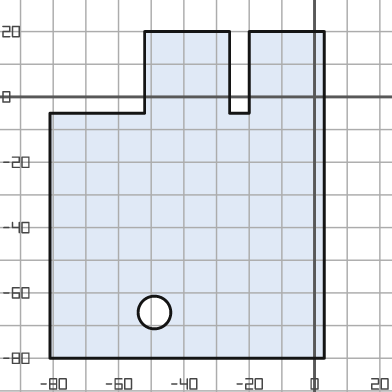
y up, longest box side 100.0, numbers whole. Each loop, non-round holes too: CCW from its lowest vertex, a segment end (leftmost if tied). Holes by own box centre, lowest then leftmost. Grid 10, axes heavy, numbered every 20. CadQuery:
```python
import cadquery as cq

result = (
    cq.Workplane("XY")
    .moveTo(-81.0, -80.0)
    .lineTo(3.0, -80.0)
    .lineTo(3.0, 20.0)
    .lineTo(-20.0, 20.0)
    .lineTo(-20.0, -5.0)
    .lineTo(-26.0, -5.0)
    .lineTo(-26.0, 20.0)
    .lineTo(-52.0, 20.0)
    .lineTo(-52.0, -5.0)
    .lineTo(-81.0, -5.0)
    .close()
    .moveTo(-49.0, -66.0)
    .circle(5.0)
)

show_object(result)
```